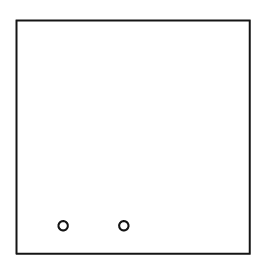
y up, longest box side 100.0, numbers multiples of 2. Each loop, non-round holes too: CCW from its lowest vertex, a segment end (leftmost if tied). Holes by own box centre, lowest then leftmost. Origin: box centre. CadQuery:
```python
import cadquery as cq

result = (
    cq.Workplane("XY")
    .moveTo(-50.0, -50.0)
    .lineTo(50.0, -50.0)
    .lineTo(50.0, 50.0)
    .lineTo(-50.0, 50.0)
    .close()
    .moveTo(-30.0, -38.0)
    .circle(2.0)
    .moveTo(-4.0, -38.0)
    .circle(2.0)
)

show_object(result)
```